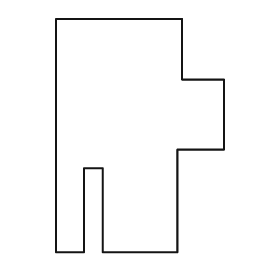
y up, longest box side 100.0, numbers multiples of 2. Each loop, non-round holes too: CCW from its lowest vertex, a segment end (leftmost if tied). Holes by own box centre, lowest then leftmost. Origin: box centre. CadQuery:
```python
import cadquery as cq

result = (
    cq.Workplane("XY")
    .moveTo(-36.0, -50.0)
    .lineTo(-24.0, -50.0)
    .lineTo(-24.0, -14.0)
    .lineTo(-16.0, -14.0)
    .lineTo(-16.0, -50.0)
    .lineTo(16.0, -50.0)
    .lineTo(16.0, -6.0)
    .lineTo(36.0, -6.0)
    .lineTo(36.0, 24.0)
    .lineTo(18.0, 24.0)
    .lineTo(18.0, 50.0)
    .lineTo(-36.0, 50.0)
    .close()
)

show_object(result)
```